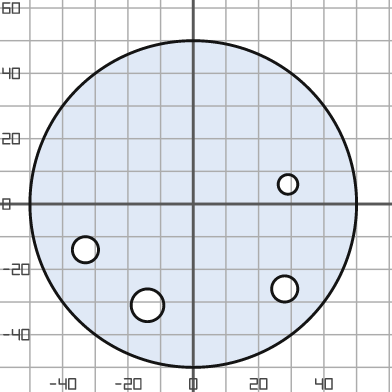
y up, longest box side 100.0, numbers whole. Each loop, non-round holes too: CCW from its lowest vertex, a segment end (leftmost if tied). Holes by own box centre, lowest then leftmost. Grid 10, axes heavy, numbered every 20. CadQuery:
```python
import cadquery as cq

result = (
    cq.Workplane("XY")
    .moveTo(0.0, 0.0)
    .circle(50.0)
    .moveTo(-14.0, -31.0)
    .circle(5.0)
    .moveTo(28.0, -26.0)
    .circle(4.0)
    .moveTo(-33.0, -14.0)
    .circle(4.0)
    .moveTo(29.0, 6.0)
    .circle(3.0)
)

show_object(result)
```